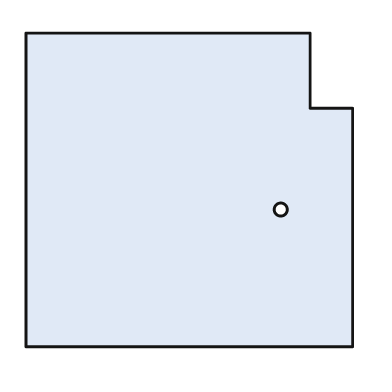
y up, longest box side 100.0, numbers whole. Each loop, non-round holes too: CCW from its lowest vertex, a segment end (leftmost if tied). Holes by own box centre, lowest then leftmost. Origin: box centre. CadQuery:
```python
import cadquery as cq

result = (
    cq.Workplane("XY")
    .moveTo(-50.0, -48.0)
    .lineTo(50.0, -48.0)
    .lineTo(50.0, 25.0)
    .lineTo(37.0, 25.0)
    .lineTo(37.0, 48.0)
    .lineTo(-50.0, 48.0)
    .close()
    .moveTo(28.0, -6.0)
    .circle(2.0)
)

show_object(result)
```